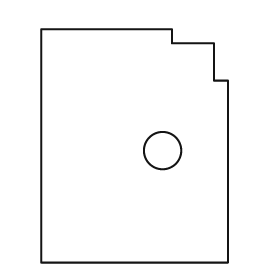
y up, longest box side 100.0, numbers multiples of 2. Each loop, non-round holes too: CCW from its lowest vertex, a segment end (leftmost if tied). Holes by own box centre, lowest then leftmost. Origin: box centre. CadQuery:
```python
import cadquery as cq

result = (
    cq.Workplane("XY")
    .moveTo(-40.0, -50.0)
    .lineTo(40.0, -50.0)
    .lineTo(40.0, 28.0)
    .lineTo(34.0, 28.0)
    .lineTo(34.0, 44.0)
    .lineTo(16.0, 44.0)
    .lineTo(16.0, 50.0)
    .lineTo(-40.0, 50.0)
    .close()
    .moveTo(12.0, -2.0)
    .circle(8.0)
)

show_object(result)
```